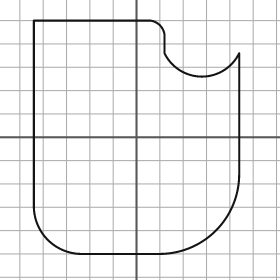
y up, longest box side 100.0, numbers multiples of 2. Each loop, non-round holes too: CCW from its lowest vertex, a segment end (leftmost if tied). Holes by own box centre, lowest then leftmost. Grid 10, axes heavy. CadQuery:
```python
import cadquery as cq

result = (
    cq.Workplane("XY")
    .moveTo(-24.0, -50.0)
    .lineTo(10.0, -50.0)
    .threePointArc((34.0, -40.0), (44.0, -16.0))
    .lineTo(44.0, 36.0)
    .threePointArc((28.0, 26.0), (12.0, 36.0))
    .lineTo(12.0, 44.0)
    .threePointArc((10.0, 48.0), (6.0, 50.0))
    .lineTo(-44.0, 50.0)
    .lineTo(-44.0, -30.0)
    .threePointArc((-38.0, -44.0), (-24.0, -50.0))
    .close()
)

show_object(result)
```